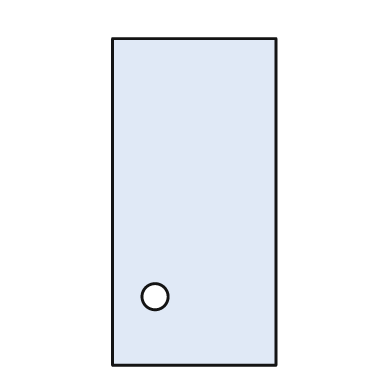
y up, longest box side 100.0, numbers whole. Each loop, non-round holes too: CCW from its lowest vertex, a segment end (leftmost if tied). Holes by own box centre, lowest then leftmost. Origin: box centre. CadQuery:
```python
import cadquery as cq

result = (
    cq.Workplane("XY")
    .moveTo(-25.0, -50.0)
    .lineTo(25.0, -50.0)
    .lineTo(25.0, 50.0)
    .lineTo(-25.0, 50.0)
    .close()
    .moveTo(-12.0, -29.0)
    .circle(4.0)
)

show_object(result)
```